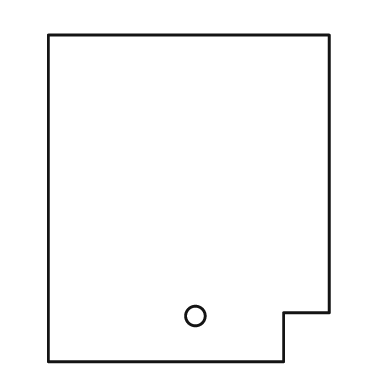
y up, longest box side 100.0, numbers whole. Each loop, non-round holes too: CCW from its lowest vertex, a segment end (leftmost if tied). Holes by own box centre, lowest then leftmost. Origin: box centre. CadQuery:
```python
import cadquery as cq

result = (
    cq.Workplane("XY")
    .moveTo(-43.0, -50.0)
    .lineTo(29.0, -50.0)
    .lineTo(29.0, -35.0)
    .lineTo(43.0, -35.0)
    .lineTo(43.0, 50.0)
    .lineTo(-43.0, 50.0)
    .close()
    .moveTo(2.0, -36.0)
    .circle(3.0)
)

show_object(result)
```